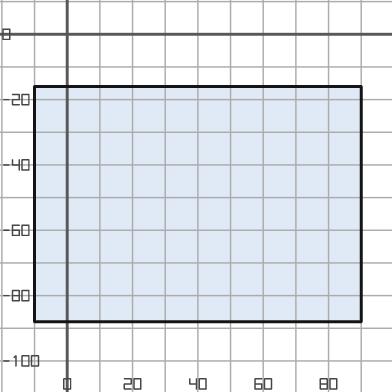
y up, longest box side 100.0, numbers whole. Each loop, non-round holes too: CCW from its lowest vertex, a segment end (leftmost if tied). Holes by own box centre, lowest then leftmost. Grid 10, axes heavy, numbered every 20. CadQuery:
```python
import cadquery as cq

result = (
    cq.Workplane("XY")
    .moveTo(-10.0, -88.0)
    .lineTo(90.0, -88.0)
    .lineTo(90.0, -16.0)
    .lineTo(-10.0, -16.0)
    .close()
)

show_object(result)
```